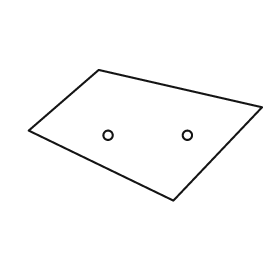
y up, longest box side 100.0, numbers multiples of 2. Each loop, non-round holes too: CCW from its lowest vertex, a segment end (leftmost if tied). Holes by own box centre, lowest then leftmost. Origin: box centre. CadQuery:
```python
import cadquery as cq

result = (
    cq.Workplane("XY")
    .moveTo(12.0, -28.0)
    .lineTo(50.0, 12.0)
    .lineTo(-20.0, 28.0)
    .lineTo(-50.0, 2.0)
    .close()
    .moveTo(-16.0, 0.0)
    .circle(2.0)
    .moveTo(18.0, 0.0)
    .circle(2.0)
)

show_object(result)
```